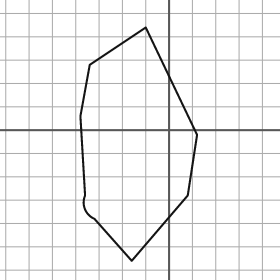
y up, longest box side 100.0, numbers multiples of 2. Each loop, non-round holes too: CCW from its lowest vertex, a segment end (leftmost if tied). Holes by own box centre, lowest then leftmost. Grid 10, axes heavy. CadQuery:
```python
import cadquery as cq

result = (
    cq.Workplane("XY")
    .moveTo(-16.0, -56.0)
    .lineTo(8.0, -28.0)
    .lineTo(12.0, -2.0)
    .lineTo(-10.0, 44.0)
    .lineTo(-34.0, 28.0)
    .lineTo(-38.0, 6.0)
    .lineTo(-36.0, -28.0)
    .threePointArc((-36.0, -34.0), (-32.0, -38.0))
    .close()
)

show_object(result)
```